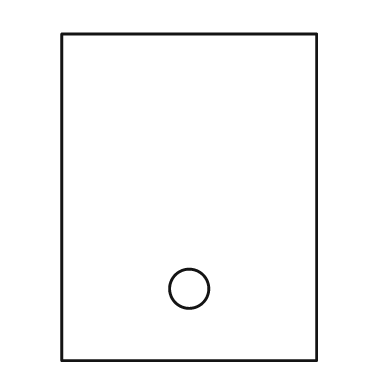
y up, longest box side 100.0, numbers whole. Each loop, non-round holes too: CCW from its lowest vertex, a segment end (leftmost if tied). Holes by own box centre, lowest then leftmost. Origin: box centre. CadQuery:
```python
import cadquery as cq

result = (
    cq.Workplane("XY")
    .moveTo(-39.0, -50.0)
    .lineTo(39.0, -50.0)
    .lineTo(39.0, 50.0)
    .lineTo(-39.0, 50.0)
    .close()
    .moveTo(0.0, -28.0)
    .circle(6.0)
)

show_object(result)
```